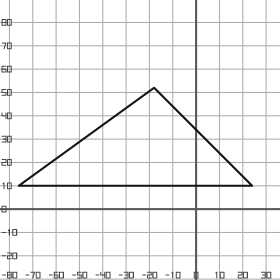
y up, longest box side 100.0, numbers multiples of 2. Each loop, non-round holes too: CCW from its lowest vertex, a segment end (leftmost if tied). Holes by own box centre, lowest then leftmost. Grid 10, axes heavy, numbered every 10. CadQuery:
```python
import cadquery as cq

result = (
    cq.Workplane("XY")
    .moveTo(-76.0, 10.0)
    .lineTo(24.0, 10.0)
    .lineTo(-18.0, 52.0)
    .close()
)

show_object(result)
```